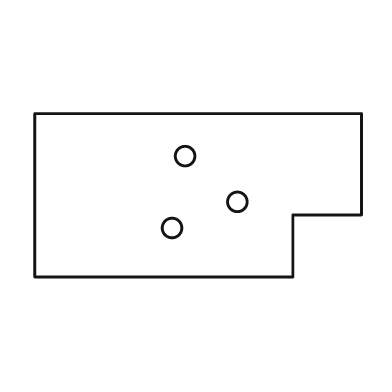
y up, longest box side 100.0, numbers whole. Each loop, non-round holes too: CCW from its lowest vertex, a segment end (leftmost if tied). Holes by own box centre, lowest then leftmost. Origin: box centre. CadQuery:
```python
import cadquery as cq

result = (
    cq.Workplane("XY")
    .moveTo(-50.0, -25.0)
    .lineTo(29.0, -25.0)
    .lineTo(29.0, -6.0)
    .lineTo(50.0, -6.0)
    .lineTo(50.0, 25.0)
    .lineTo(-50.0, 25.0)
    .close()
    .moveTo(-8.0, -10.0)
    .circle(3.0)
    .moveTo(12.0, -2.0)
    .circle(3.0)
    .moveTo(-4.0, 12.0)
    .circle(3.0)
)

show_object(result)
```